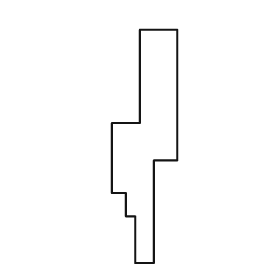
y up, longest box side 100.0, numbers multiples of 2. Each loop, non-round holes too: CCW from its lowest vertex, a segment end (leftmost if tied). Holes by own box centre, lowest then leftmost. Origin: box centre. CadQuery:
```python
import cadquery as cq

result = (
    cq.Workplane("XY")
    .moveTo(-4.0, -50.0)
    .lineTo(4.0, -50.0)
    .lineTo(4.0, -6.0)
    .lineTo(14.0, -6.0)
    .lineTo(14.0, 50.0)
    .lineTo(-2.0, 50.0)
    .lineTo(-2.0, 10.0)
    .lineTo(-14.0, 10.0)
    .lineTo(-14.0, -20.0)
    .lineTo(-8.0, -20.0)
    .lineTo(-8.0, -30.0)
    .lineTo(-4.0, -30.0)
    .close()
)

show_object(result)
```